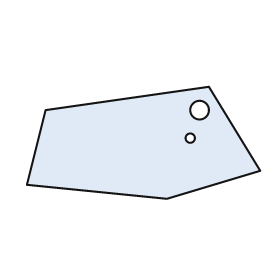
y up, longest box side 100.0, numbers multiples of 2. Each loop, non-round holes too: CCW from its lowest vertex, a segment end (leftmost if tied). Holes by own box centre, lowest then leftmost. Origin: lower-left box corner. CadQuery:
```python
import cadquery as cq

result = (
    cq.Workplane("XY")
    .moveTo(60.0, 0.0)
    .lineTo(100.0, 12.0)
    .lineTo(78.0, 48.0)
    .lineTo(8.0, 38.0)
    .lineTo(0.0, 6.0)
    .close()
    .moveTo(70.0, 26.0)
    .circle(2.0)
    .moveTo(74.0, 38.0)
    .circle(4.0)
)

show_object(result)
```